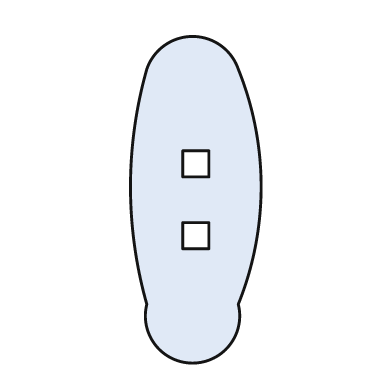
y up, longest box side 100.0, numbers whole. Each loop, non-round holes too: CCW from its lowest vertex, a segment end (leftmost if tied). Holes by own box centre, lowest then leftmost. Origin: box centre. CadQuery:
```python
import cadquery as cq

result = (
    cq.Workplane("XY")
    .moveTo(-15.0, -32.0)
    .threePointArc((-1.0, -50.0), (13.0, -32.0))
    .threePointArc((20.0, 4.0), (13.0, 40.0))
    .threePointArc((-1.0, 50.0), (-15.0, 40.0))
    .threePointArc((-20.0, 4.0), (-15.0, -32.0))
    .close()
    .moveTo(-4.0, -15.0)
    .lineTo(4.0, -15.0)
    .lineTo(4.0, -7.0)
    .lineTo(-4.0, -7.0)
    .close()
    .moveTo(-4.0, 7.0)
    .lineTo(4.0, 7.0)
    .lineTo(4.0, 15.0)
    .lineTo(-4.0, 15.0)
    .close()
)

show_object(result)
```